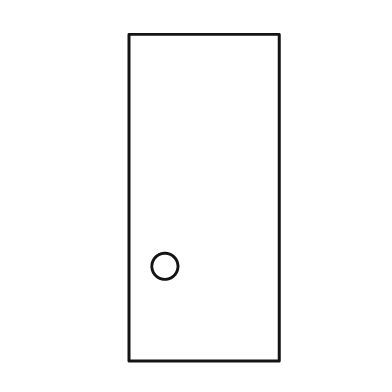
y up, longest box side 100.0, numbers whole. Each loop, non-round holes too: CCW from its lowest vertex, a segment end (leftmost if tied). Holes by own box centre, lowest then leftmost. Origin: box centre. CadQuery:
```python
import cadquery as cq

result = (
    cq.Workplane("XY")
    .moveTo(-23.0, -50.0)
    .lineTo(23.0, -50.0)
    .lineTo(23.0, 50.0)
    .lineTo(-23.0, 50.0)
    .close()
    .moveTo(-12.0, -21.0)
    .circle(4.0)
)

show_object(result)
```